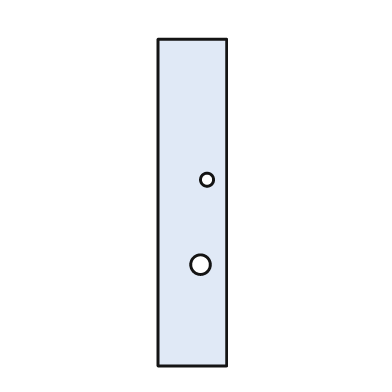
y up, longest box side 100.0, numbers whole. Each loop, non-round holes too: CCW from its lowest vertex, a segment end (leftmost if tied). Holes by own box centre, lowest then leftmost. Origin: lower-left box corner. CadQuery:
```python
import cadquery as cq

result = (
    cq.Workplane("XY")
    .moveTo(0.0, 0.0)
    .lineTo(21.0, 0.0)
    .lineTo(21.0, 100.0)
    .lineTo(0.0, 100.0)
    .close()
    .moveTo(13.0, 31.0)
    .circle(3.0)
    .moveTo(15.0, 57.0)
    .circle(2.0)
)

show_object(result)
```